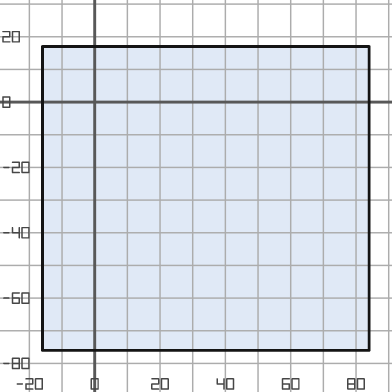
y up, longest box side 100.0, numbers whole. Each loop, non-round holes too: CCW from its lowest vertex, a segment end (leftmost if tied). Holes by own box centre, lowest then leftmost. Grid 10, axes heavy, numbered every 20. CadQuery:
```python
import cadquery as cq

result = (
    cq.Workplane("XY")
    .moveTo(-16.0, -76.0)
    .lineTo(84.0, -76.0)
    .lineTo(84.0, 17.0)
    .lineTo(-16.0, 17.0)
    .close()
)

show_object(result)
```